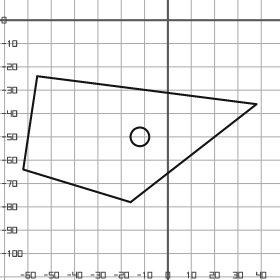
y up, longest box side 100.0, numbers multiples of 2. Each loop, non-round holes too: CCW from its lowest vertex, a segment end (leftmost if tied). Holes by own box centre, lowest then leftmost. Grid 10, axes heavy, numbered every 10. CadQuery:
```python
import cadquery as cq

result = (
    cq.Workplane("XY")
    .moveTo(-16.0, -78.0)
    .lineTo(38.0, -36.0)
    .lineTo(-56.0, -24.0)
    .lineTo(-62.0, -64.0)
    .close()
    .moveTo(-12.0, -50.0)
    .circle(4.0)
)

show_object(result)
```